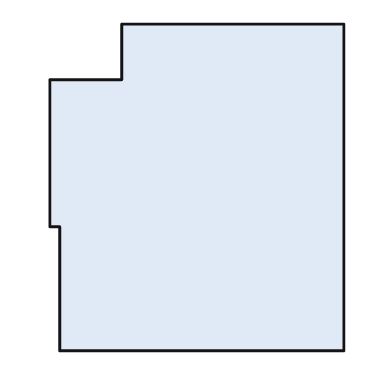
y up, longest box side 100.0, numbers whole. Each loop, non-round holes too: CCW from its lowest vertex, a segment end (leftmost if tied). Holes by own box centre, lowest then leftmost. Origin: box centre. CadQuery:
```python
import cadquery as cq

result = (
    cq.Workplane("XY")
    .moveTo(-42.0, -50.0)
    .lineTo(45.0, -50.0)
    .lineTo(45.0, 50.0)
    .lineTo(-23.0, 50.0)
    .lineTo(-23.0, 33.0)
    .lineTo(-45.0, 33.0)
    .lineTo(-45.0, -12.0)
    .lineTo(-42.0, -12.0)
    .close()
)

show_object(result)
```